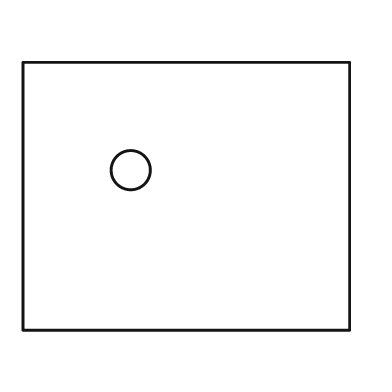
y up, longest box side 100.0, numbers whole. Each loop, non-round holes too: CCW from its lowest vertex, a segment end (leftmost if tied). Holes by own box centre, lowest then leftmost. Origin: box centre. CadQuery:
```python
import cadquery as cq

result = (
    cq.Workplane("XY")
    .moveTo(-50.0, -41.0)
    .lineTo(50.0, -41.0)
    .lineTo(50.0, 41.0)
    .lineTo(-50.0, 41.0)
    .close()
    .moveTo(-17.0, 8.0)
    .circle(6.0)
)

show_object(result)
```